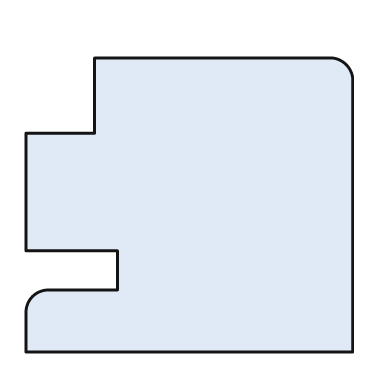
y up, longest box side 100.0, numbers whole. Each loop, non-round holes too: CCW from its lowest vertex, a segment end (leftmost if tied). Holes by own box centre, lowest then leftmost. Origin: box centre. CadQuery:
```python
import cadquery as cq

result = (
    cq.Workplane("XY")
    .moveTo(-50.0, -45.0)
    .lineTo(50.0, -45.0)
    .lineTo(50.0, 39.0)
    .threePointArc((48.0, 43.0), (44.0, 45.0))
    .lineTo(-29.0, 45.0)
    .lineTo(-29.0, 22.0)
    .lineTo(-50.0, 22.0)
    .lineTo(-50.0, -14.0)
    .lineTo(-22.0, -14.0)
    .lineTo(-22.0, -26.0)
    .lineTo(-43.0, -26.0)
    .threePointArc((-48.0, -28.0), (-50.0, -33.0))
    .close()
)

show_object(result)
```